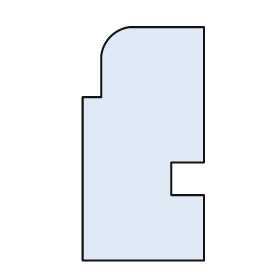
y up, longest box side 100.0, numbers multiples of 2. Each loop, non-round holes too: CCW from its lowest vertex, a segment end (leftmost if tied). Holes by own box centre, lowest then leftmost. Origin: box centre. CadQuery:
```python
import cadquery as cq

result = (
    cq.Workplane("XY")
    .moveTo(-26.0, -50.0)
    .lineTo(26.0, -50.0)
    .lineTo(26.0, -22.0)
    .lineTo(12.0, -22.0)
    .lineTo(12.0, -8.0)
    .lineTo(26.0, -8.0)
    .lineTo(26.0, 50.0)
    .lineTo(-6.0, 50.0)
    .threePointArc((-14.0, 46.0), (-18.0, 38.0))
    .lineTo(-18.0, 20.0)
    .lineTo(-26.0, 20.0)
    .close()
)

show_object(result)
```